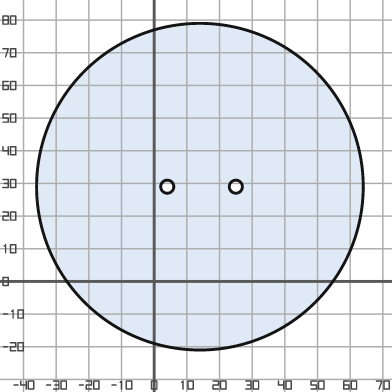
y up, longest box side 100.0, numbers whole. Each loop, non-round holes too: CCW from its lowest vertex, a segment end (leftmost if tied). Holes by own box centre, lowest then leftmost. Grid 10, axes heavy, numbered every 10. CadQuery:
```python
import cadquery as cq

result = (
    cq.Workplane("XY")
    .moveTo(14.0, 29.0)
    .circle(50.0)
    .moveTo(4.0, 29.0)
    .circle(2.0)
    .moveTo(25.0, 29.0)
    .circle(2.0)
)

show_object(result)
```